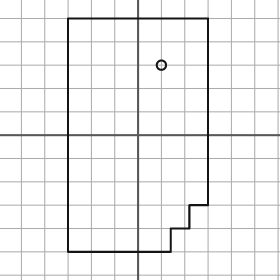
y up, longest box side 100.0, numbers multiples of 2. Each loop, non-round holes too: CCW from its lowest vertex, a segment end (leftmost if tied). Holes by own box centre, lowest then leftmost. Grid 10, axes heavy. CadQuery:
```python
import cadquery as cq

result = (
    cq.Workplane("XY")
    .moveTo(-30.0, -50.0)
    .lineTo(14.0, -50.0)
    .lineTo(14.0, -40.0)
    .lineTo(22.0, -40.0)
    .lineTo(22.0, -30.0)
    .lineTo(30.0, -30.0)
    .lineTo(30.0, 50.0)
    .lineTo(-30.0, 50.0)
    .close()
    .moveTo(10.0, 30.0)
    .circle(2.0)
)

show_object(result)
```